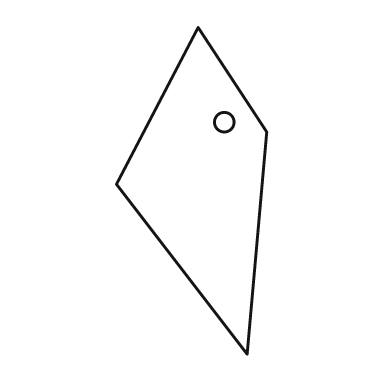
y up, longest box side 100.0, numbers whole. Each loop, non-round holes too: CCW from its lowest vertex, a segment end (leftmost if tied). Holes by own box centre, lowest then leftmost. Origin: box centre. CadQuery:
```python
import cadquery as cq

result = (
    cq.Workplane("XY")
    .moveTo(17.0, -50.0)
    .lineTo(23.0, 18.0)
    .lineTo(2.0, 50.0)
    .lineTo(-23.0, 2.0)
    .close()
    .moveTo(10.0, 21.0)
    .circle(3.0)
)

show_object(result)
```